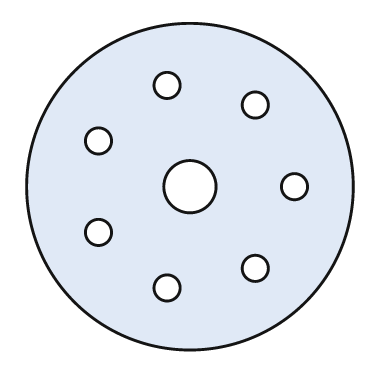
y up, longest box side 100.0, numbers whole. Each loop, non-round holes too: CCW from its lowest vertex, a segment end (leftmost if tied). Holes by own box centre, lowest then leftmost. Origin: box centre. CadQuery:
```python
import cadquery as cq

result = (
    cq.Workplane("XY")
    .moveTo(0.0, 0.0)
    .circle(50.0)
    .moveTo(-7.0, -31.0)
    .circle(4.0)
    .moveTo(20.0, -25.0)
    .circle(4.0)
    .moveTo(-28.0, -14.0)
    .circle(4.0)
    .moveTo(0.0, 0.0)
    .circle(8.0)
    .moveTo(32.0, 0.0)
    .circle(4.0)
    .moveTo(-28.0, 14.0)
    .circle(4.0)
    .moveTo(20.0, 25.0)
    .circle(4.0)
    .moveTo(-7.0, 31.0)
    .circle(4.0)
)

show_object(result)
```